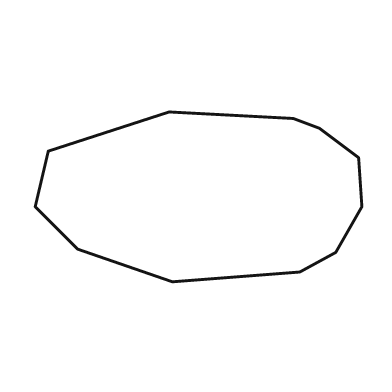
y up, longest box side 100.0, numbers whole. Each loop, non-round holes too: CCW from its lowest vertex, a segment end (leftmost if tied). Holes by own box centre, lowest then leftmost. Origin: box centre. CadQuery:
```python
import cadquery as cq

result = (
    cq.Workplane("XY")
    .moveTo(-8.0, -26.0)
    .lineTo(31.0, -23.0)
    .lineTo(42.0, -17.0)
    .lineTo(50.0, -3.0)
    .lineTo(49.0, 12.0)
    .lineTo(37.0, 21.0)
    .lineTo(29.0, 24.0)
    .lineTo(-9.0, 26.0)
    .lineTo(-46.0, 14.0)
    .lineTo(-50.0, -3.0)
    .lineTo(-37.0, -16.0)
    .close()
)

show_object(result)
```